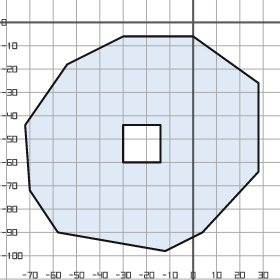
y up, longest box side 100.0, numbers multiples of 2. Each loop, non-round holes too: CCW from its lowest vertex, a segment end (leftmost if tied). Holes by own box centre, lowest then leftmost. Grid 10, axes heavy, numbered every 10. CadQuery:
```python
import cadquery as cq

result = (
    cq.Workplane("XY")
    .moveTo(-12.0, -98.0)
    .lineTo(4.0, -90.0)
    .lineTo(28.0, -64.0)
    .lineTo(28.0, -26.0)
    .lineTo(0.0, -6.0)
    .lineTo(-30.0, -6.0)
    .lineTo(-54.0, -18.0)
    .lineTo(-72.0, -44.0)
    .lineTo(-70.0, -72.0)
    .lineTo(-58.0, -90.0)
    .close()
    .moveTo(-30.0, -60.0)
    .lineTo(-14.0, -60.0)
    .lineTo(-14.0, -44.0)
    .lineTo(-30.0, -44.0)
    .close()
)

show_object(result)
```